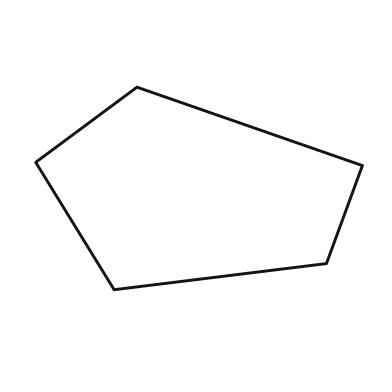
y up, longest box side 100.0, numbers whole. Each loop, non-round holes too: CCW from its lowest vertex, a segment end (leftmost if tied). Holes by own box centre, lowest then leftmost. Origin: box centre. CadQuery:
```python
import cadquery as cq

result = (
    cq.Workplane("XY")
    .moveTo(-26.0, -31.0)
    .lineTo(39.0, -23.0)
    .lineTo(50.0, 7.0)
    .lineTo(-19.0, 31.0)
    .lineTo(-50.0, 8.0)
    .close()
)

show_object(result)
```